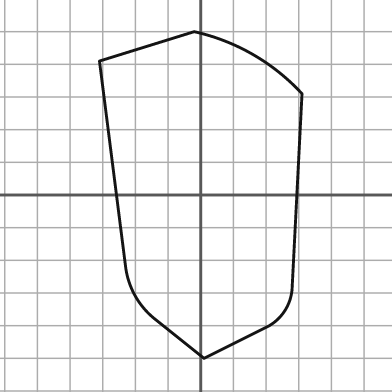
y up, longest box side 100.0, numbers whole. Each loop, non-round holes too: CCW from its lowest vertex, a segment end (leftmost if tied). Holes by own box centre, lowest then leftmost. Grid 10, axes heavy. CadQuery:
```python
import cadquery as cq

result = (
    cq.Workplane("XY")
    .moveTo(1.0, -50.0)
    .lineTo(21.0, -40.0)
    .threePointArc((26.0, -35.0), (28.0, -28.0))
    .lineTo(31.0, 31.0)
    .threePointArc((16.0, 43.0), (-2.0, 50.0))
    .lineTo(-31.0, 41.0)
    .lineTo(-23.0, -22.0)
    .threePointArc((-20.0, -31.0), (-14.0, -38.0))
    .close()
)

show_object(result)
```